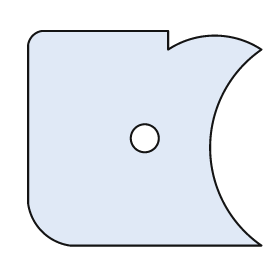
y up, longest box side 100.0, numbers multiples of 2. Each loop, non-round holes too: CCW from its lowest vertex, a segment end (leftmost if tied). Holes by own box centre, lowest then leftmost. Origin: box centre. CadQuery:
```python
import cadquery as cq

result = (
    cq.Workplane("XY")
    .moveTo(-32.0, -46.0)
    .lineTo(50.0, -46.0)
    .threePointArc((28.0, -4.0), (50.0, 38.0))
    .threePointArc((30.0, 44.0), (10.0, 38.0))
    .lineTo(10.0, 46.0)
    .lineTo(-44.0, 46.0)
    .threePointArc((-48.0, 44.0), (-50.0, 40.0))
    .lineTo(-50.0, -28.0)
    .threePointArc((-44.0, -40.0), (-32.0, -46.0))
    .close()
    .moveTo(0.0, 0.0)
    .circle(6.0)
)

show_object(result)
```